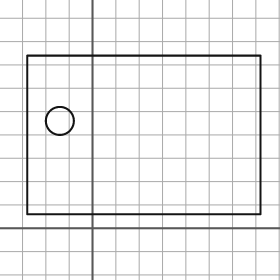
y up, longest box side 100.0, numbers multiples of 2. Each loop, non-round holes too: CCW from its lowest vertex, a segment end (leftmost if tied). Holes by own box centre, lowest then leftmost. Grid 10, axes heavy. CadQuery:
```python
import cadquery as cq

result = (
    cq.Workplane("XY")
    .moveTo(-28.0, 6.0)
    .lineTo(72.0, 6.0)
    .lineTo(72.0, 74.0)
    .lineTo(-28.0, 74.0)
    .close()
    .moveTo(-14.0, 46.0)
    .circle(6.0)
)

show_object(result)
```